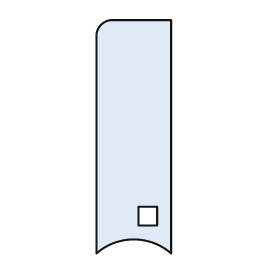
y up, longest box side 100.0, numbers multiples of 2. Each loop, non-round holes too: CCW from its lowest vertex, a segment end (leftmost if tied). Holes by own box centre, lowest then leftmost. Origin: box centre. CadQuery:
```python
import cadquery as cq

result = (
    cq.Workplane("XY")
    .moveTo(-16.0, -50.0)
    .threePointArc((0.0, -44.0), (16.0, -50.0))
    .lineTo(16.0, 50.0)
    .lineTo(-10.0, 50.0)
    .threePointArc((-14.0, 48.0), (-16.0, 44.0))
    .close()
    .moveTo(2.0, -38.0)
    .lineTo(10.0, -38.0)
    .lineTo(10.0, -30.0)
    .lineTo(2.0, -30.0)
    .close()
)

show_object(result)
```